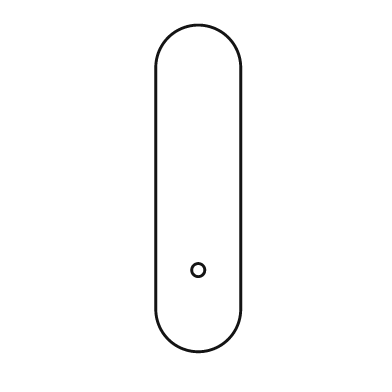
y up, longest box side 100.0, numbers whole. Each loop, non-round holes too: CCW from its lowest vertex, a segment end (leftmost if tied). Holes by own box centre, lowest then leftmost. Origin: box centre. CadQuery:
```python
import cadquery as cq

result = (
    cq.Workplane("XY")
    .moveTo(-13.0, -37.0)
    .threePointArc((0.0, -50.0), (13.0, -37.0))
    .lineTo(13.0, 37.0)
    .threePointArc((0.0, 50.0), (-13.0, 37.0))
    .close()
    .moveTo(0.0, -25.0)
    .circle(2.0)
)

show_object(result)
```